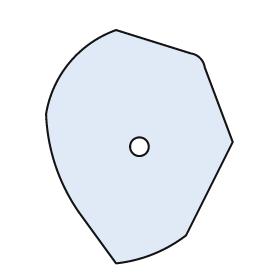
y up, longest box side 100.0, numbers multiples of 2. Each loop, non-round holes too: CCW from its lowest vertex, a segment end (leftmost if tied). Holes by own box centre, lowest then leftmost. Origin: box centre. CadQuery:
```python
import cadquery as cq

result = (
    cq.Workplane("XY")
    .moveTo(-10.0, -50.0)
    .threePointArc((6.0, -46.0), (20.0, -38.0))
    .lineTo(40.0, 2.0)
    .lineTo(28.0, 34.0)
    .threePointArc((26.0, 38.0), (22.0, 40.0))
    .lineTo(-10.0, 50.0)
    .threePointArc((-30.0, 36.0), (-40.0, 14.0))
    .threePointArc((-36.0, -8.0), (-26.0, -28.0))
    .close()
    .moveTo(0.0, 0.0)
    .circle(4.0)
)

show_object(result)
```